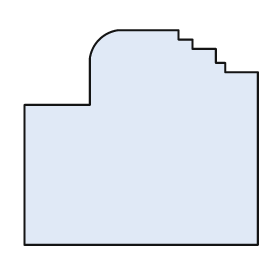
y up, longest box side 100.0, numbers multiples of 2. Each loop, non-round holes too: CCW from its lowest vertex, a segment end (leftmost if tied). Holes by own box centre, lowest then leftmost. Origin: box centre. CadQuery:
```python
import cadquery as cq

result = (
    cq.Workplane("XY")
    .moveTo(-50.0, -46.0)
    .lineTo(50.0, -46.0)
    .lineTo(50.0, 28.0)
    .lineTo(36.0, 28.0)
    .lineTo(36.0, 32.0)
    .lineTo(32.0, 32.0)
    .lineTo(32.0, 38.0)
    .lineTo(22.0, 38.0)
    .lineTo(22.0, 42.0)
    .lineTo(16.0, 42.0)
    .lineTo(16.0, 46.0)
    .lineTo(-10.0, 46.0)
    .threePointArc((-18.0, 42.0), (-22.0, 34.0))
    .lineTo(-22.0, 14.0)
    .lineTo(-50.0, 14.0)
    .close()
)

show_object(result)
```